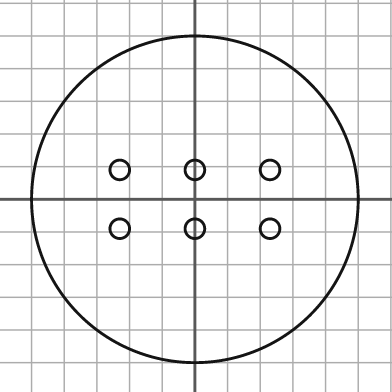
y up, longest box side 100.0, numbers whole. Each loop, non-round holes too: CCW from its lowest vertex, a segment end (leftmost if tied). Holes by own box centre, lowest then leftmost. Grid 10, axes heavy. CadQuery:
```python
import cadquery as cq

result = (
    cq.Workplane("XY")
    .moveTo(0.0, 0.0)
    .circle(50.0)
    .moveTo(-23.0, -9.0)
    .circle(3.0)
    .moveTo(0.0, -9.0)
    .circle(3.0)
    .moveTo(23.0, -9.0)
    .circle(3.0)
    .moveTo(-23.0, 9.0)
    .circle(3.0)
    .moveTo(0.0, 9.0)
    .circle(3.0)
    .moveTo(23.0, 9.0)
    .circle(3.0)
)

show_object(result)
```